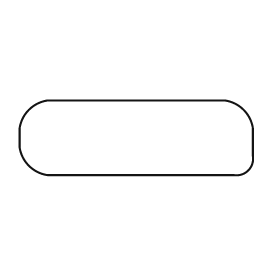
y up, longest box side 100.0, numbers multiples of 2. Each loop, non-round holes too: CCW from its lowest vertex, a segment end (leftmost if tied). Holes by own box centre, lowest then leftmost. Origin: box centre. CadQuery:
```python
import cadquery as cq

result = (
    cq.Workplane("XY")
    .moveTo(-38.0, -16.0)
    .lineTo(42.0, -16.0)
    .threePointArc((48.0, -14.0), (50.0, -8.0))
    .lineTo(50.0, 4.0)
    .threePointArc((46.0, 12.0), (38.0, 16.0))
    .lineTo(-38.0, 16.0)
    .threePointArc((-46.0, 12.0), (-50.0, 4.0))
    .lineTo(-50.0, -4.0)
    .threePointArc((-46.0, -12.0), (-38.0, -16.0))
    .close()
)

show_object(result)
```